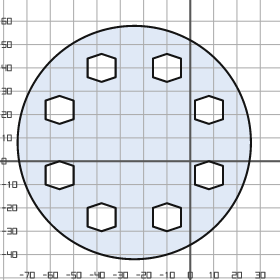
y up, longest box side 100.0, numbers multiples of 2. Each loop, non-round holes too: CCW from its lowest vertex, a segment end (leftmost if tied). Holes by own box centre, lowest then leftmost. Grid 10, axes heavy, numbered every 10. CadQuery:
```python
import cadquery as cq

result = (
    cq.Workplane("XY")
    .moveTo(-24.0, 8.0)
    .circle(50.0)
    .moveTo(-38.0, -30.0)
    .lineTo(-32.0, -28.0)
    .lineTo(-32.0, -20.0)
    .lineTo(-38.0, -18.0)
    .lineTo(-44.0, -20.0)
    .lineTo(-44.0, -28.0)
    .close()
    .moveTo(-10.0, -30.0)
    .lineTo(-4.0, -28.0)
    .lineTo(-4.0, -20.0)
    .lineTo(-10.0, -18.0)
    .lineTo(-16.0, -20.0)
    .lineTo(-16.0, -28.0)
    .close()
    .moveTo(-56.0, -12.0)
    .lineTo(-50.0, -10.0)
    .lineTo(-50.0, -2.0)
    .lineTo(-56.0, 0.0)
    .lineTo(-62.0, -2.0)
    .lineTo(-62.0, -10.0)
    .close()
    .moveTo(8.0, -12.0)
    .lineTo(14.0, -10.0)
    .lineTo(14.0, -2.0)
    .lineTo(8.0, 0.0)
    .lineTo(2.0, -2.0)
    .lineTo(2.0, -10.0)
    .close()
    .moveTo(-56.0, 16.0)
    .lineTo(-50.0, 18.0)
    .lineTo(-50.0, 26.0)
    .lineTo(-56.0, 28.0)
    .lineTo(-62.0, 26.0)
    .lineTo(-62.0, 18.0)
    .close()
    .moveTo(8.0, 16.0)
    .lineTo(14.0, 18.0)
    .lineTo(14.0, 26.0)
    .lineTo(8.0, 28.0)
    .lineTo(2.0, 26.0)
    .lineTo(2.0, 18.0)
    .close()
    .moveTo(-38.0, 34.0)
    .lineTo(-32.0, 36.0)
    .lineTo(-32.0, 44.0)
    .lineTo(-38.0, 46.0)
    .lineTo(-44.0, 44.0)
    .lineTo(-44.0, 36.0)
    .close()
    .moveTo(-10.0, 34.0)
    .lineTo(-4.0, 36.0)
    .lineTo(-4.0, 44.0)
    .lineTo(-10.0, 46.0)
    .lineTo(-16.0, 44.0)
    .lineTo(-16.0, 36.0)
    .close()
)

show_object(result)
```